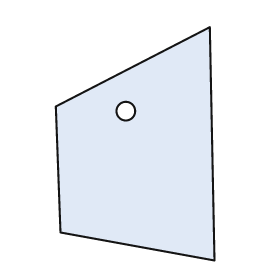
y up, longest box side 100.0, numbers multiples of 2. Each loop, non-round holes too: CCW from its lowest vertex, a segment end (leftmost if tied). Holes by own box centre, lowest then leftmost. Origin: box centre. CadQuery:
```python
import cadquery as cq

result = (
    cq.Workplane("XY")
    .moveTo(34.0, -50.0)
    .lineTo(32.0, 50.0)
    .lineTo(-34.0, 16.0)
    .lineTo(-32.0, -38.0)
    .close()
    .moveTo(-4.0, 14.0)
    .circle(4.0)
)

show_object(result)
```